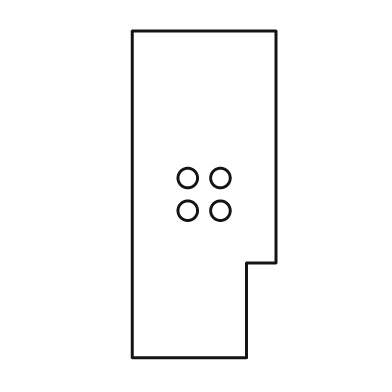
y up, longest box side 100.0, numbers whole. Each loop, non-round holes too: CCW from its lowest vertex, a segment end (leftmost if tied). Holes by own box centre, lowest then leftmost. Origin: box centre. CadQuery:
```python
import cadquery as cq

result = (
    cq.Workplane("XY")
    .moveTo(-22.0, -50.0)
    .lineTo(13.0, -50.0)
    .lineTo(13.0, -21.0)
    .lineTo(22.0, -21.0)
    .lineTo(22.0, 50.0)
    .lineTo(-22.0, 50.0)
    .close()
    .moveTo(-5.0, -5.0)
    .circle(3.0)
    .moveTo(5.0, -5.0)
    .circle(3.0)
    .moveTo(-5.0, 5.0)
    .circle(3.0)
    .moveTo(5.0, 5.0)
    .circle(3.0)
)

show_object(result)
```